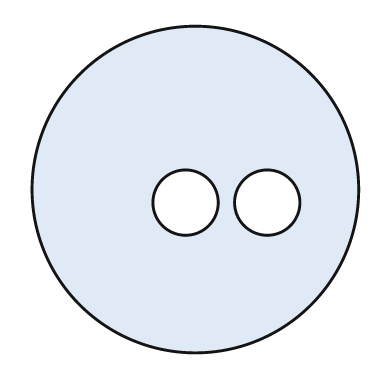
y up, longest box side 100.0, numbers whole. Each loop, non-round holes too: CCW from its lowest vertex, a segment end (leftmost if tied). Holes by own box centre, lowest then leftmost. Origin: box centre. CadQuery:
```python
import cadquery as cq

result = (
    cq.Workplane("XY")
    .moveTo(0.0, 0.0)
    .circle(50.0)
    .moveTo(-3.0, -4.0)
    .circle(10.0)
    .moveTo(22.0, -4.0)
    .circle(10.0)
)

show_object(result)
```